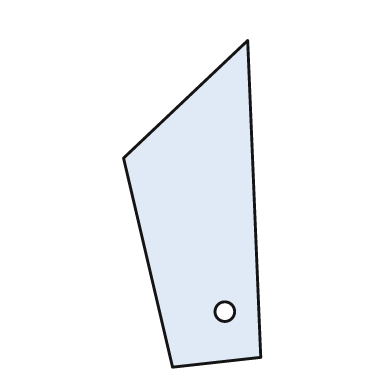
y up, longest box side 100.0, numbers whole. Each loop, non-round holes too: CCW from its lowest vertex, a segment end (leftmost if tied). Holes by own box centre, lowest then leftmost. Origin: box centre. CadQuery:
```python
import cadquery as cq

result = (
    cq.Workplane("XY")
    .moveTo(-6.0, -50.0)
    .lineTo(21.0, -47.0)
    .lineTo(17.0, 50.0)
    .lineTo(-21.0, 14.0)
    .close()
    .moveTo(10.0, -33.0)
    .circle(3.0)
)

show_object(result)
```